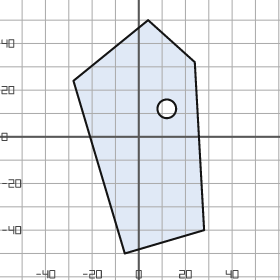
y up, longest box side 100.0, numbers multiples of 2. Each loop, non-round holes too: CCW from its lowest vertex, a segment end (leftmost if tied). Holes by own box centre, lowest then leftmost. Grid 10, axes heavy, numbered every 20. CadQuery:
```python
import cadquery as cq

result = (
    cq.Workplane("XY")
    .moveTo(-6.0, -50.0)
    .lineTo(28.0, -40.0)
    .lineTo(24.0, 32.0)
    .lineTo(4.0, 50.0)
    .lineTo(-28.0, 24.0)
    .close()
    .moveTo(12.0, 12.0)
    .circle(4.0)
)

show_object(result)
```